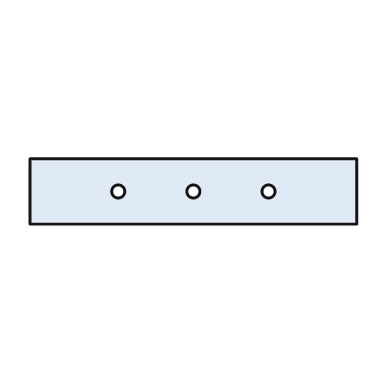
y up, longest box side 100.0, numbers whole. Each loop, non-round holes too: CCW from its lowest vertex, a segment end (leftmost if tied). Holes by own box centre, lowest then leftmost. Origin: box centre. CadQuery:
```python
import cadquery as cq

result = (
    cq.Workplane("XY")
    .moveTo(-50.0, -10.0)
    .lineTo(50.0, -10.0)
    .lineTo(50.0, 10.0)
    .lineTo(-50.0, 10.0)
    .close()
    .moveTo(-23.0, 0.0)
    .circle(2.0)
    .moveTo(0.0, 0.0)
    .circle(2.0)
    .moveTo(23.0, 0.0)
    .circle(2.0)
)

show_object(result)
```